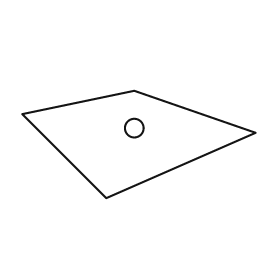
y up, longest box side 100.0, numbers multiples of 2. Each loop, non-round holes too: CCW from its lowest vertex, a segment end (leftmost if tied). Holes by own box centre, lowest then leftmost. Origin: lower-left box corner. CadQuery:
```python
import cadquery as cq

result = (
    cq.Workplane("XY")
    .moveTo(36.0, 0.0)
    .lineTo(100.0, 28.0)
    .lineTo(48.0, 46.0)
    .lineTo(0.0, 36.0)
    .close()
    .moveTo(48.0, 30.0)
    .circle(4.0)
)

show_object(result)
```